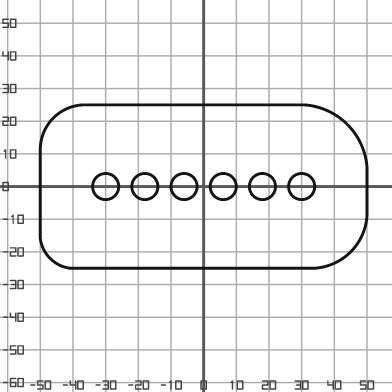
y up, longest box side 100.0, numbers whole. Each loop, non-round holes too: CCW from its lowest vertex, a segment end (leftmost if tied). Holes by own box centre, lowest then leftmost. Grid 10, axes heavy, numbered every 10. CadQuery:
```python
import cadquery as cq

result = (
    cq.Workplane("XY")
    .moveTo(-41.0, -25.0)
    .lineTo(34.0, -25.0)
    .threePointArc((45.0, -20.0), (50.0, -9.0))
    .lineTo(50.0, 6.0)
    .threePointArc((44.0, 19.0), (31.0, 25.0))
    .lineTo(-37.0, 25.0)
    .threePointArc((-46.0, 21.0), (-50.0, 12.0))
    .lineTo(-50.0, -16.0)
    .threePointArc((-47.0, -22.0), (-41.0, -25.0))
    .close()
    .moveTo(-30.0, 0.0)
    .circle(4.0)
    .moveTo(-18.0, 0.0)
    .circle(4.0)
    .moveTo(-6.0, 0.0)
    .circle(4.0)
    .moveTo(6.0, 0.0)
    .circle(4.0)
    .moveTo(18.0, 0.0)
    .circle(4.0)
    .moveTo(30.0, 0.0)
    .circle(4.0)
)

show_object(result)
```